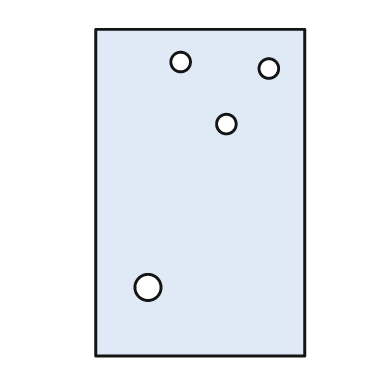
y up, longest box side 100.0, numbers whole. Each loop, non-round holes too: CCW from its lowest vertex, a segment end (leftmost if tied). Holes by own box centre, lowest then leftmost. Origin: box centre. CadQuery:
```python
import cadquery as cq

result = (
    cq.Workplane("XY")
    .moveTo(-32.0, -50.0)
    .lineTo(32.0, -50.0)
    .lineTo(32.0, 50.0)
    .lineTo(-32.0, 50.0)
    .close()
    .moveTo(-16.0, -29.0)
    .circle(4.0)
    .moveTo(8.0, 21.0)
    .circle(3.0)
    .moveTo(21.0, 38.0)
    .circle(3.0)
    .moveTo(-6.0, 40.0)
    .circle(3.0)
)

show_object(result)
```